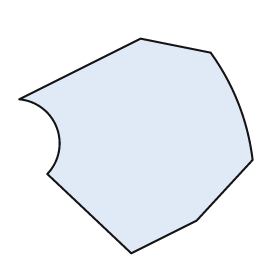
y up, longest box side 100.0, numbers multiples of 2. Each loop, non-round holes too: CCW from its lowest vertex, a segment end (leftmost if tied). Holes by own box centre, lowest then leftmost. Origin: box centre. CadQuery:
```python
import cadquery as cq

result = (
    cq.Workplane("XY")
    .moveTo(-2.0, -46.0)
    .lineTo(26.0, -32.0)
    .lineTo(50.0, -6.0)
    .threePointArc((44.0, 18.0), (32.0, 40.0))
    .lineTo(2.0, 46.0)
    .lineTo(-50.0, 20.0)
    .threePointArc((-34.0, 8.0), (-38.0, -12.0))
    .close()
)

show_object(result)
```